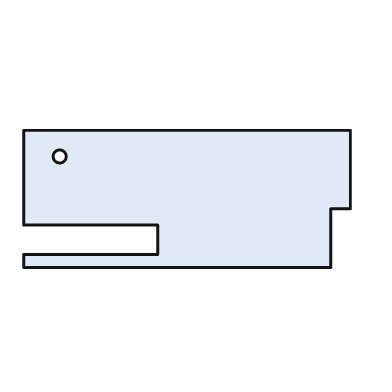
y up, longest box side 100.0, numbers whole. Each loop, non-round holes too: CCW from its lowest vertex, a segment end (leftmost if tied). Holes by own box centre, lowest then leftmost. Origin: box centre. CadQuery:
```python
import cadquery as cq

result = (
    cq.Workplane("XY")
    .moveTo(-50.0, -21.0)
    .lineTo(44.0, -21.0)
    .lineTo(44.0, -3.0)
    .lineTo(50.0, -3.0)
    .lineTo(50.0, 21.0)
    .lineTo(-50.0, 21.0)
    .lineTo(-50.0, -8.0)
    .lineTo(-9.0, -8.0)
    .lineTo(-9.0, -17.0)
    .lineTo(-50.0, -17.0)
    .close()
    .moveTo(-39.0, 13.0)
    .circle(2.0)
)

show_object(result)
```